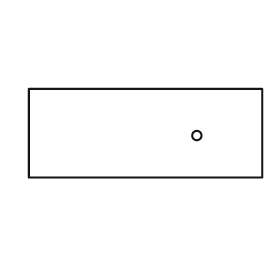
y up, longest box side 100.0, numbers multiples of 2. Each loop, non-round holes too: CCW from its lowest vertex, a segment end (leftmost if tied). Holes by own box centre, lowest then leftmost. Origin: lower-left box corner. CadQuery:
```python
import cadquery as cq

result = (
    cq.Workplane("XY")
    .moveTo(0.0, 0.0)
    .lineTo(100.0, 0.0)
    .lineTo(100.0, 38.0)
    .lineTo(0.0, 38.0)
    .close()
    .moveTo(72.0, 18.0)
    .circle(2.0)
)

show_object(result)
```